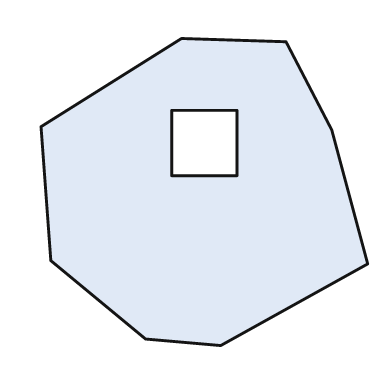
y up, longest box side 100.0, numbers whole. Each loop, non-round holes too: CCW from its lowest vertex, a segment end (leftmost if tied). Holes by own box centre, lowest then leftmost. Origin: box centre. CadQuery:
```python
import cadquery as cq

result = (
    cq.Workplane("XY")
    .moveTo(5.0, -47.0)
    .lineTo(50.0, -22.0)
    .lineTo(39.0, 19.0)
    .lineTo(25.0, 46.0)
    .lineTo(-7.0, 47.0)
    .lineTo(-50.0, 20.0)
    .lineTo(-47.0, -21.0)
    .lineTo(-18.0, -45.0)
    .close()
    .moveTo(-10.0, 5.0)
    .lineTo(10.0, 5.0)
    .lineTo(10.0, 25.0)
    .lineTo(-10.0, 25.0)
    .close()
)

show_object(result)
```